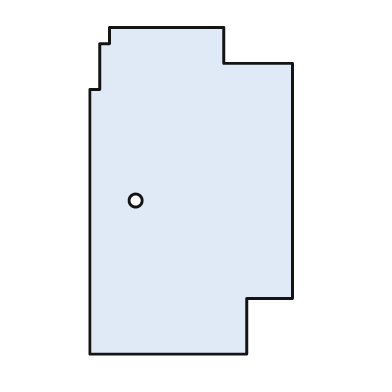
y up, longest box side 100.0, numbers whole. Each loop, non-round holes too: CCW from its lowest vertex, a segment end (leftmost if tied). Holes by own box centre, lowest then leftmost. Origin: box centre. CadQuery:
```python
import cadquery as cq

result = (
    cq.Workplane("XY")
    .moveTo(-31.0, -50.0)
    .lineTo(17.0, -50.0)
    .lineTo(17.0, -33.0)
    .lineTo(31.0, -33.0)
    .lineTo(31.0, 39.0)
    .lineTo(10.0, 39.0)
    .lineTo(10.0, 50.0)
    .lineTo(-25.0, 50.0)
    .lineTo(-25.0, 45.0)
    .lineTo(-28.0, 45.0)
    .lineTo(-28.0, 31.0)
    .lineTo(-31.0, 31.0)
    .close()
    .moveTo(-17.0, -3.0)
    .circle(2.0)
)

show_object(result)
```